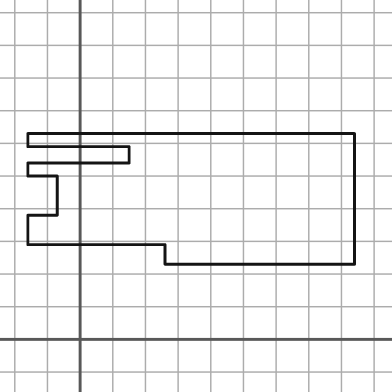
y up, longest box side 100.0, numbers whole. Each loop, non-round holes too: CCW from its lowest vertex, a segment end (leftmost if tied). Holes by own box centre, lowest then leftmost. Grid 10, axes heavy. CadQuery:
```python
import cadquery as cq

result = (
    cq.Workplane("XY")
    .moveTo(26.0, 23.0)
    .lineTo(84.0, 23.0)
    .lineTo(84.0, 63.0)
    .lineTo(-16.0, 63.0)
    .lineTo(-16.0, 59.0)
    .lineTo(15.0, 59.0)
    .lineTo(15.0, 54.0)
    .lineTo(-16.0, 54.0)
    .lineTo(-16.0, 50.0)
    .lineTo(-7.0, 50.0)
    .lineTo(-7.0, 38.0)
    .lineTo(-16.0, 38.0)
    .lineTo(-16.0, 29.0)
    .lineTo(26.0, 29.0)
    .close()
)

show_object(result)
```